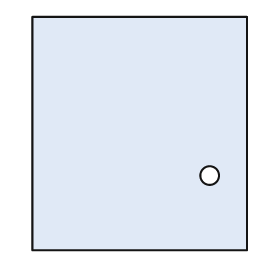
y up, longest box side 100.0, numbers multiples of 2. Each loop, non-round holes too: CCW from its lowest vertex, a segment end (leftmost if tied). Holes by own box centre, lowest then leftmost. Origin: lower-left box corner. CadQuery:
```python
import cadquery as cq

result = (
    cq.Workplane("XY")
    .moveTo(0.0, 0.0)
    .lineTo(92.0, 0.0)
    .lineTo(92.0, 100.0)
    .lineTo(0.0, 100.0)
    .close()
    .moveTo(76.0, 32.0)
    .circle(4.0)
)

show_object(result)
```